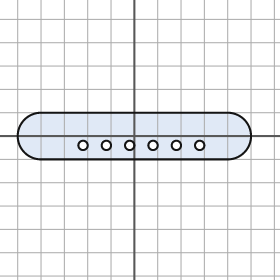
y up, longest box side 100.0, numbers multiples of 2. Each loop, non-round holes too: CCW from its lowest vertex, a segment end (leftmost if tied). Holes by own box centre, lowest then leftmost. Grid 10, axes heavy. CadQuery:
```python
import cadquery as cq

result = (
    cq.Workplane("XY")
    .moveTo(-40.0, -10.0)
    .lineTo(40.0, -10.0)
    .threePointArc((50.0, 0.0), (40.0, 10.0))
    .lineTo(-40.0, 10.0)
    .threePointArc((-50.0, 0.0), (-40.0, -10.0))
    .close()
    .moveTo(-22.0, -4.0)
    .circle(2.0)
    .moveTo(-12.0, -4.0)
    .circle(2.0)
    .moveTo(-2.0, -4.0)
    .circle(2.0)
    .moveTo(8.0, -4.0)
    .circle(2.0)
    .moveTo(18.0, -4.0)
    .circle(2.0)
    .moveTo(28.0, -4.0)
    .circle(2.0)
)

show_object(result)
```